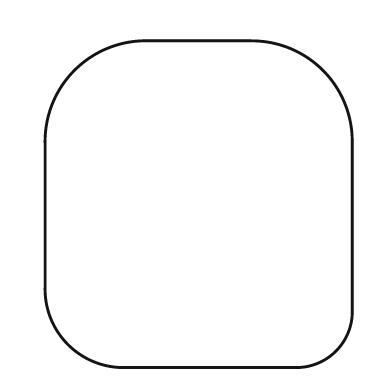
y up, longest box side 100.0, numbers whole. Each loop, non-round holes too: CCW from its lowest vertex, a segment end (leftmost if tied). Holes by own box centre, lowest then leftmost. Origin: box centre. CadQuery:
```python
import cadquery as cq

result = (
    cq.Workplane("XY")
    .moveTo(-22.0, -50.0)
    .lineTo(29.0, -50.0)
    .threePointArc((42.0, -45.0), (47.0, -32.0))
    .lineTo(47.0, 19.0)
    .threePointArc((38.0, 41.0), (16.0, 50.0))
    .lineTo(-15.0, 50.0)
    .threePointArc((-38.0, 41.0), (-47.0, 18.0))
    .lineTo(-47.0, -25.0)
    .threePointArc((-40.0, -43.0), (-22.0, -50.0))
    .close()
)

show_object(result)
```